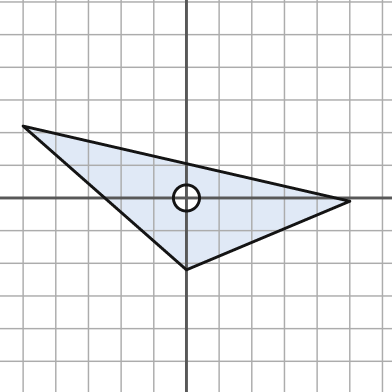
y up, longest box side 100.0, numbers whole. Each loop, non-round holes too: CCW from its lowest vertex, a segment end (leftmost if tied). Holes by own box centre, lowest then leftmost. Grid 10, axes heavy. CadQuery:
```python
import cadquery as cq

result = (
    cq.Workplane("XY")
    .moveTo(0.0, -22.0)
    .lineTo(50.0, -1.0)
    .lineTo(-50.0, 22.0)
    .close()
    .moveTo(0.0, 0.0)
    .circle(4.0)
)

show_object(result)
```